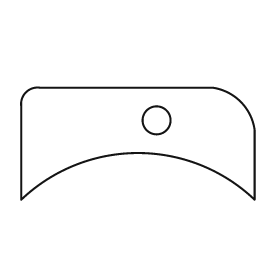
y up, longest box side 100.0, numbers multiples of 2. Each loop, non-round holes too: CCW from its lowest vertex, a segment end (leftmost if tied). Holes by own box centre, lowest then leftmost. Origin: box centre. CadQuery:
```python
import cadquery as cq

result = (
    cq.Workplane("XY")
    .moveTo(-50.0, -24.0)
    .threePointArc((0.0, -4.0), (50.0, -24.0))
    .lineTo(50.0, 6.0)
    .threePointArc((44.0, 18.0), (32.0, 24.0))
    .lineTo(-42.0, 24.0)
    .threePointArc((-48.0, 22.0), (-50.0, 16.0))
    .close()
    .moveTo(8.0, 10.0)
    .circle(6.0)
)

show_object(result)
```